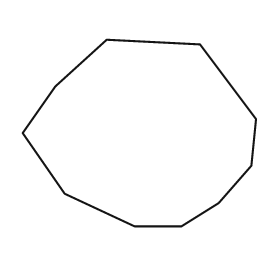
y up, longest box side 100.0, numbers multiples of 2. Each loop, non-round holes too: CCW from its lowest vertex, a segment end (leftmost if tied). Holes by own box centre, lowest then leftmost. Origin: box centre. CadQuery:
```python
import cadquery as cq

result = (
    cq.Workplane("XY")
    .moveTo(-2.0, -40.0)
    .lineTo(18.0, -40.0)
    .lineTo(34.0, -30.0)
    .lineTo(48.0, -14.0)
    .lineTo(50.0, 6.0)
    .lineTo(26.0, 38.0)
    .lineTo(-14.0, 40.0)
    .lineTo(-36.0, 20.0)
    .lineTo(-50.0, 0.0)
    .lineTo(-32.0, -26.0)
    .close()
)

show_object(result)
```